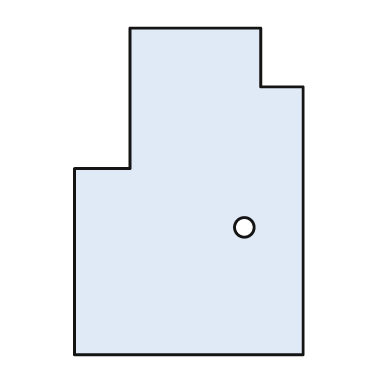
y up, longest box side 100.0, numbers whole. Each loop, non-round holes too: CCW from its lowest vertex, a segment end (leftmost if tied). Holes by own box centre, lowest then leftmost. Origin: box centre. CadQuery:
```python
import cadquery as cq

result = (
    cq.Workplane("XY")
    .moveTo(-35.0, -50.0)
    .lineTo(35.0, -50.0)
    .lineTo(35.0, 32.0)
    .lineTo(22.0, 32.0)
    .lineTo(22.0, 50.0)
    .lineTo(-18.0, 50.0)
    .lineTo(-18.0, 7.0)
    .lineTo(-35.0, 7.0)
    .close()
    .moveTo(17.0, -11.0)
    .circle(3.0)
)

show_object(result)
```